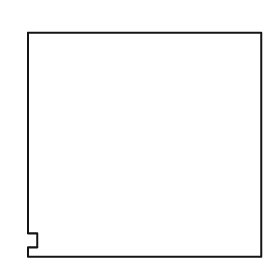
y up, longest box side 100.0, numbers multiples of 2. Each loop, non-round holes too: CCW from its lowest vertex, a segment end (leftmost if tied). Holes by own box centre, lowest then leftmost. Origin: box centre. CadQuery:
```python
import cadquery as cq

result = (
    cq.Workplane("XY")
    .moveTo(-50.0, -48.0)
    .lineTo(50.0, -48.0)
    .lineTo(50.0, 48.0)
    .lineTo(-50.0, 48.0)
    .lineTo(-50.0, -38.0)
    .lineTo(-46.0, -38.0)
    .lineTo(-46.0, -44.0)
    .lineTo(-50.0, -44.0)
    .close()
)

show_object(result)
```